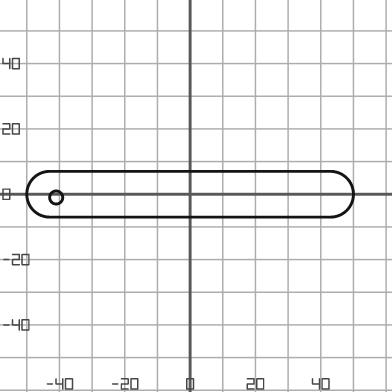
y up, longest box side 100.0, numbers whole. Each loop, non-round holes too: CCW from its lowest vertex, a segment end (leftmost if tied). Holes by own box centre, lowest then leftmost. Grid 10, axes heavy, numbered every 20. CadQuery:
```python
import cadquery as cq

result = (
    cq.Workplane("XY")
    .moveTo(-43.0, -7.0)
    .lineTo(43.0, -7.0)
    .threePointArc((50.0, 0.0), (43.0, 7.0))
    .lineTo(-43.0, 7.0)
    .threePointArc((-50.0, 0.0), (-43.0, -7.0))
    .close()
    .moveTo(-41.0, -1.0)
    .circle(2.0)
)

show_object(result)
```